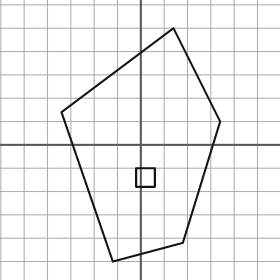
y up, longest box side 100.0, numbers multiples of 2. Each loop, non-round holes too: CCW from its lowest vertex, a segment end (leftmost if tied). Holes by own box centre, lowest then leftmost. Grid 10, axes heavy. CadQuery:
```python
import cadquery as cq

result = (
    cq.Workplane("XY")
    .moveTo(-12.0, -50.0)
    .lineTo(18.0, -42.0)
    .lineTo(34.0, 10.0)
    .lineTo(14.0, 50.0)
    .lineTo(-34.0, 14.0)
    .close()
    .moveTo(-2.0, -18.0)
    .lineTo(6.0, -18.0)
    .lineTo(6.0, -10.0)
    .lineTo(-2.0, -10.0)
    .close()
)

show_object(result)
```